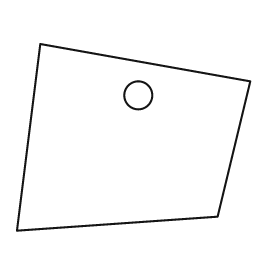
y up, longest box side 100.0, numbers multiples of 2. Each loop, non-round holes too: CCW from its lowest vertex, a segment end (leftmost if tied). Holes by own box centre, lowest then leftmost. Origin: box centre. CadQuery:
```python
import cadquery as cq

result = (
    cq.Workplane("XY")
    .moveTo(-50.0, -40.0)
    .lineTo(36.0, -34.0)
    .lineTo(50.0, 24.0)
    .lineTo(-40.0, 40.0)
    .close()
    .moveTo(2.0, 18.0)
    .circle(6.0)
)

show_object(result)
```